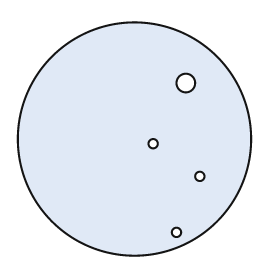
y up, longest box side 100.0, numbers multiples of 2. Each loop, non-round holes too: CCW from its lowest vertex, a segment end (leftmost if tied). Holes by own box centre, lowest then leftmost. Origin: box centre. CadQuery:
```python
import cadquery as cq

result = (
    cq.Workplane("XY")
    .moveTo(0.0, 0.0)
    .circle(50.0)
    .moveTo(18.0, -40.0)
    .circle(2.0)
    .moveTo(28.0, -16.0)
    .circle(2.0)
    .moveTo(8.0, -2.0)
    .circle(2.0)
    .moveTo(22.0, 24.0)
    .circle(4.0)
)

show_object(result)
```